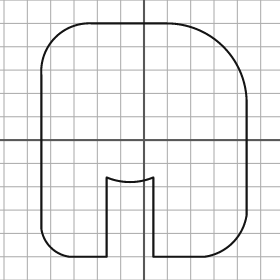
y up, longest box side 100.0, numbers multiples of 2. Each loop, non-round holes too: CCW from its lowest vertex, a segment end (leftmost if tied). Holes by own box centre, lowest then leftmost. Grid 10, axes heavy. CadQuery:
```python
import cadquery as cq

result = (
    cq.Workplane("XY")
    .moveTo(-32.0, -50.0)
    .lineTo(-16.0, -50.0)
    .lineTo(-16.0, -16.0)
    .threePointArc((-6.0, -18.0), (4.0, -16.0))
    .lineTo(4.0, -50.0)
    .lineTo(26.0, -50.0)
    .threePointArc((38.0, -44.0), (44.0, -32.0))
    .lineTo(44.0, 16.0)
    .threePointArc((34.0, 40.0), (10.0, 50.0))
    .lineTo(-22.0, 50.0)
    .threePointArc((-38.0, 44.0), (-44.0, 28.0))
    .lineTo(-44.0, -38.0)
    .threePointArc((-40.0, -46.0), (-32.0, -50.0))
    .close()
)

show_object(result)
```